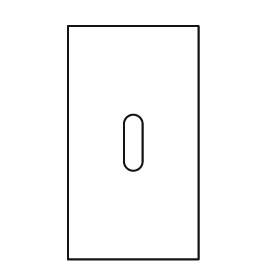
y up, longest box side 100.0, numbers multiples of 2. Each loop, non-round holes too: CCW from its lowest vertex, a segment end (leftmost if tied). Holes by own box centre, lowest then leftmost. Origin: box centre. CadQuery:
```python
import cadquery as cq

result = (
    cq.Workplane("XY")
    .moveTo(-28.0, -50.0)
    .lineTo(28.0, -50.0)
    .lineTo(28.0, 50.0)
    .lineTo(-28.0, 50.0)
    .close()
    .moveTo(-4.0, -8.0)
    .threePointArc((0.0, -12.0), (4.0, -8.0))
    .lineTo(4.0, 8.0)
    .threePointArc((0.0, 12.0), (-4.0, 8.0))
    .close()
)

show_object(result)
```